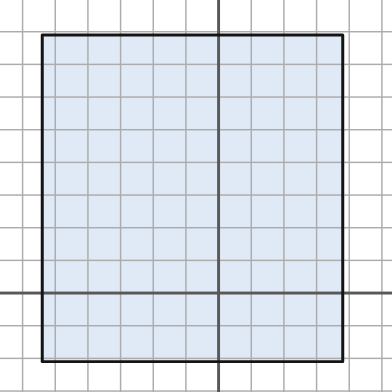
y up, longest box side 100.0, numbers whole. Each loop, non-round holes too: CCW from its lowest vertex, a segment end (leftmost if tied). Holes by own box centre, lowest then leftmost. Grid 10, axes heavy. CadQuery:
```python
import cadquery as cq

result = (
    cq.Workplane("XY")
    .moveTo(-54.0, -21.0)
    .lineTo(38.0, -21.0)
    .lineTo(38.0, 79.0)
    .lineTo(-54.0, 79.0)
    .close()
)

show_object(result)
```